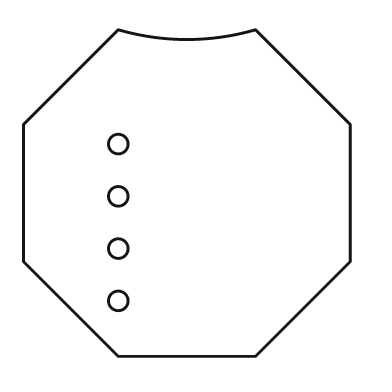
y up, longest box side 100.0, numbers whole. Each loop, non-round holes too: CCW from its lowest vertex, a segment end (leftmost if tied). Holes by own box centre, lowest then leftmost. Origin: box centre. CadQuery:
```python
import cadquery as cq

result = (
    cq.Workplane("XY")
    .moveTo(-21.0, -50.0)
    .lineTo(21.0, -50.0)
    .lineTo(50.0, -21.0)
    .lineTo(50.0, 21.0)
    .lineTo(21.0, 50.0)
    .threePointArc((0.0, 47.0), (-21.0, 50.0))
    .lineTo(-50.0, 21.0)
    .lineTo(-50.0, -21.0)
    .close()
    .moveTo(-21.0, -33.0)
    .circle(3.0)
    .moveTo(-21.0, -17.0)
    .circle(3.0)
    .moveTo(-21.0, -1.0)
    .circle(3.0)
    .moveTo(-21.0, 15.0)
    .circle(3.0)
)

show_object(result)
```